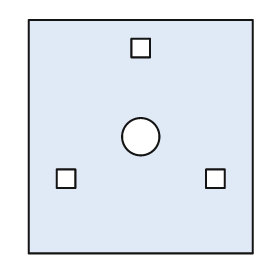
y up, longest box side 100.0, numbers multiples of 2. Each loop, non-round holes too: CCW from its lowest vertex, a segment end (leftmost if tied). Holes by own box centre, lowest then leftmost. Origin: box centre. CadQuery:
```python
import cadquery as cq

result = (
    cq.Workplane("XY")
    .moveTo(-48.0, -50.0)
    .lineTo(48.0, -50.0)
    .lineTo(48.0, 50.0)
    .lineTo(-48.0, 50.0)
    .close()
    .moveTo(-36.0, -22.0)
    .lineTo(-28.0, -22.0)
    .lineTo(-28.0, -14.0)
    .lineTo(-36.0, -14.0)
    .close()
    .moveTo(28.0, -22.0)
    .lineTo(36.0, -22.0)
    .lineTo(36.0, -14.0)
    .lineTo(28.0, -14.0)
    .close()
    .moveTo(0.0, 0.0)
    .circle(8.0)
    .moveTo(-4.0, 34.0)
    .lineTo(4.0, 34.0)
    .lineTo(4.0, 42.0)
    .lineTo(-4.0, 42.0)
    .close()
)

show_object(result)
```